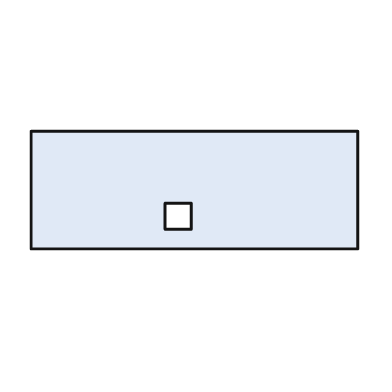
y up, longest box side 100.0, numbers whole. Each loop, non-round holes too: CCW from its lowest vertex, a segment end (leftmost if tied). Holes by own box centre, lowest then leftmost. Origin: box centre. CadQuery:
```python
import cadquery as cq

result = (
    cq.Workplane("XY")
    .moveTo(-50.0, -18.0)
    .lineTo(50.0, -18.0)
    .lineTo(50.0, 18.0)
    .lineTo(-50.0, 18.0)
    .close()
    .moveTo(-9.0, -12.0)
    .lineTo(-1.0, -12.0)
    .lineTo(-1.0, -4.0)
    .lineTo(-9.0, -4.0)
    .close()
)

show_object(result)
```